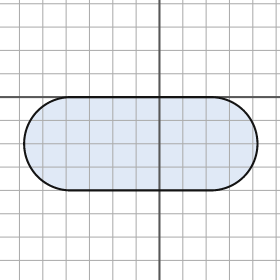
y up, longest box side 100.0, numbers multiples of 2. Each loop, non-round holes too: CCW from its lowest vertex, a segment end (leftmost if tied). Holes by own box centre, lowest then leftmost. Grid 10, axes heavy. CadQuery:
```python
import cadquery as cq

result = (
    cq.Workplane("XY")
    .moveTo(-38.0, -40.0)
    .lineTo(22.0, -40.0)
    .threePointArc((42.0, -20.0), (22.0, 0.0))
    .lineTo(-38.0, 0.0)
    .threePointArc((-58.0, -20.0), (-38.0, -40.0))
    .close()
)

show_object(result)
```